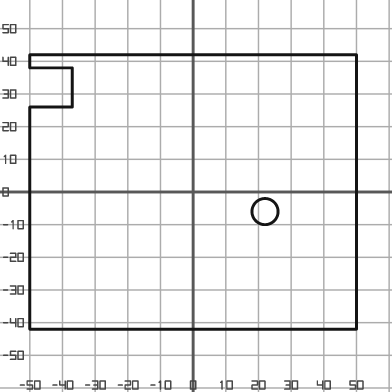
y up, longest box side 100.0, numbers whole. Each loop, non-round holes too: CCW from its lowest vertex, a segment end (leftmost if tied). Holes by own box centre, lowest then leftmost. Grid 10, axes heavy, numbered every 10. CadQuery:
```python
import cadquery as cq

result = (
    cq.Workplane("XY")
    .moveTo(-50.0, -42.0)
    .lineTo(50.0, -42.0)
    .lineTo(50.0, 42.0)
    .lineTo(-50.0, 42.0)
    .lineTo(-50.0, 38.0)
    .lineTo(-37.0, 38.0)
    .lineTo(-37.0, 26.0)
    .lineTo(-50.0, 26.0)
    .close()
    .moveTo(22.0, -6.0)
    .circle(4.0)
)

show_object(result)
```